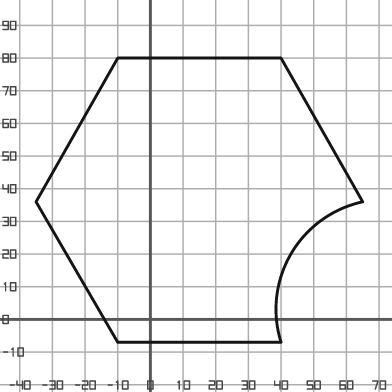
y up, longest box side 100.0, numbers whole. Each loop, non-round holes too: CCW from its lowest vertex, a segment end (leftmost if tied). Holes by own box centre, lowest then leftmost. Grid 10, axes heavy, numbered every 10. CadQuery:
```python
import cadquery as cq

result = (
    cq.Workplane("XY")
    .moveTo(-10.0, -7.0)
    .lineTo(40.0, -7.0)
    .threePointArc((43.0, 20.0), (65.0, 36.0))
    .lineTo(40.0, 80.0)
    .lineTo(-10.0, 80.0)
    .lineTo(-35.0, 36.0)
    .close()
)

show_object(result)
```